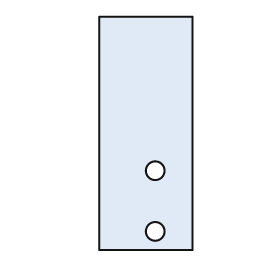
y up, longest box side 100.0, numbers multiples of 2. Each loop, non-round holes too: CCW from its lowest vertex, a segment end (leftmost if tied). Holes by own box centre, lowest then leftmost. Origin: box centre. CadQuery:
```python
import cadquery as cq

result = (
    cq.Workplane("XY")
    .moveTo(-20.0, -50.0)
    .lineTo(20.0, -50.0)
    .lineTo(20.0, 50.0)
    .lineTo(-20.0, 50.0)
    .close()
    .moveTo(4.0, -42.0)
    .circle(4.0)
    .moveTo(4.0, -16.0)
    .circle(4.0)
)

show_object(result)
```